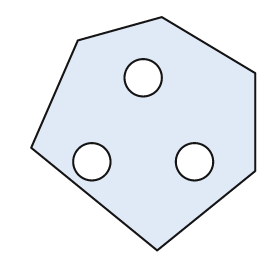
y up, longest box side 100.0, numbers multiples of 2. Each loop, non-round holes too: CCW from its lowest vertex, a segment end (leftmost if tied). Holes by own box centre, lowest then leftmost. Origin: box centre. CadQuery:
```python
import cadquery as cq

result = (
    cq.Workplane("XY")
    .moveTo(6.0, -50.0)
    .lineTo(48.0, -16.0)
    .lineTo(48.0, 26.0)
    .lineTo(8.0, 50.0)
    .lineTo(-28.0, 40.0)
    .lineTo(-48.0, -6.0)
    .close()
    .moveTo(-22.0, -12.0)
    .circle(8.0)
    .moveTo(22.0, -12.0)
    .circle(8.0)
    .moveTo(0.0, 24.0)
    .circle(8.0)
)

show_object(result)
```